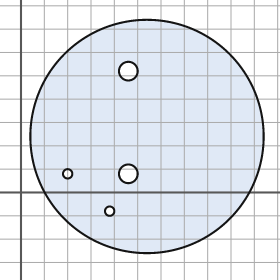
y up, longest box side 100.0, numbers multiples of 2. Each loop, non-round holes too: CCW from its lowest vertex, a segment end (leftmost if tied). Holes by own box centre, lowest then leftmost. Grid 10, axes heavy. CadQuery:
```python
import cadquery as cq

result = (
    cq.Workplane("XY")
    .moveTo(54.0, 24.0)
    .circle(50.0)
    .moveTo(38.0, -8.0)
    .circle(2.0)
    .moveTo(20.0, 8.0)
    .circle(2.0)
    .moveTo(46.0, 8.0)
    .circle(4.0)
    .moveTo(46.0, 52.0)
    .circle(4.0)
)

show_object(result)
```